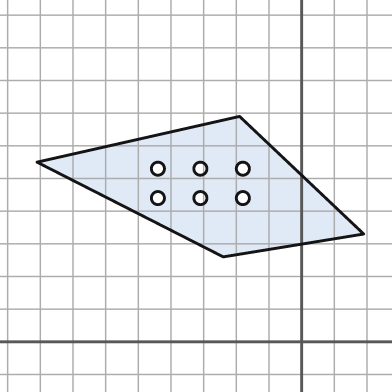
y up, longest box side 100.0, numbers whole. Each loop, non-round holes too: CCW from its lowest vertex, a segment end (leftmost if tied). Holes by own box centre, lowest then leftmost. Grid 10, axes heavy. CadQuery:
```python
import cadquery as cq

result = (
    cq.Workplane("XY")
    .moveTo(-24.0, 26.0)
    .lineTo(19.0, 33.0)
    .lineTo(-19.0, 69.0)
    .lineTo(-81.0, 55.0)
    .close()
    .moveTo(-44.0, 44.0)
    .circle(2.0)
    .moveTo(-31.0, 44.0)
    .circle(2.0)
    .moveTo(-18.0, 44.0)
    .circle(2.0)
    .moveTo(-44.0, 53.0)
    .circle(2.0)
    .moveTo(-31.0, 53.0)
    .circle(2.0)
    .moveTo(-18.0, 53.0)
    .circle(2.0)
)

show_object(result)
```